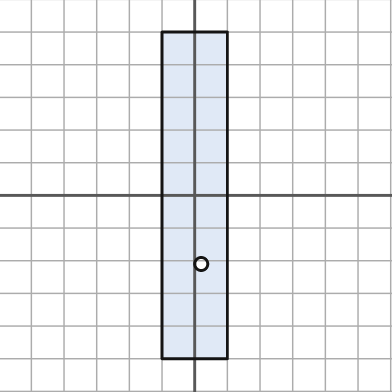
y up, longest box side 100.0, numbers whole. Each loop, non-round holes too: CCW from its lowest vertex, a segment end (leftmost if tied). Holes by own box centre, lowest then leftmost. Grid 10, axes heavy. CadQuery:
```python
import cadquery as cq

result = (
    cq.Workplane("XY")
    .moveTo(-10.0, -50.0)
    .lineTo(10.0, -50.0)
    .lineTo(10.0, 50.0)
    .lineTo(-10.0, 50.0)
    .close()
    .moveTo(2.0, -21.0)
    .circle(2.0)
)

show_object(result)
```